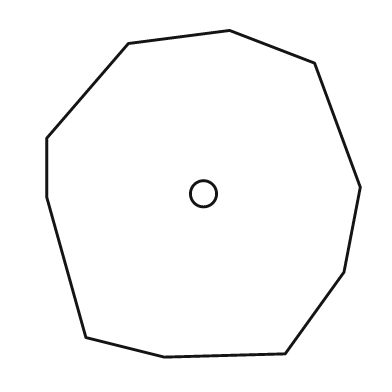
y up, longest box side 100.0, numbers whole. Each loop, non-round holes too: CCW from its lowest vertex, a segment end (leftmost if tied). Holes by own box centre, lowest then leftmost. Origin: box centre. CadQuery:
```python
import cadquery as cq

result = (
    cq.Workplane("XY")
    .moveTo(-12.0, -50.0)
    .lineTo(25.0, -49.0)
    .lineTo(43.0, -24.0)
    .lineTo(48.0, 2.0)
    .lineTo(34.0, 40.0)
    .lineTo(8.0, 50.0)
    .lineTo(-23.0, 46.0)
    .lineTo(-48.0, 17.0)
    .lineTo(-48.0, -1.0)
    .lineTo(-36.0, -44.0)
    .close()
    .moveTo(0.0, 0.0)
    .circle(4.0)
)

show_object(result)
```